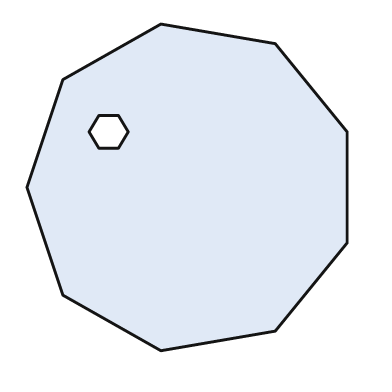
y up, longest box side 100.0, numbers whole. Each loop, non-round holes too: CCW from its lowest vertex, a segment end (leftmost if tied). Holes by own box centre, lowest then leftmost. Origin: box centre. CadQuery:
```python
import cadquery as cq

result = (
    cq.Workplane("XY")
    .moveTo(-8.0, -50.0)
    .lineTo(27.0, -44.0)
    .lineTo(49.0, -17.0)
    .lineTo(49.0, 17.0)
    .lineTo(27.0, 44.0)
    .lineTo(-8.0, 50.0)
    .lineTo(-38.0, 33.0)
    .lineTo(-49.0, 0.0)
    .lineTo(-38.0, -33.0)
    .close()
    .moveTo(-27.0, 12.0)
    .lineTo(-21.0, 12.0)
    .lineTo(-18.0, 17.0)
    .lineTo(-21.0, 22.0)
    .lineTo(-27.0, 22.0)
    .lineTo(-30.0, 17.0)
    .close()
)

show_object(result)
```